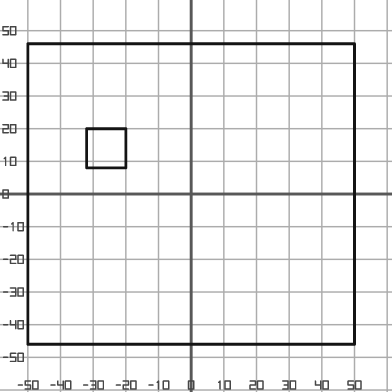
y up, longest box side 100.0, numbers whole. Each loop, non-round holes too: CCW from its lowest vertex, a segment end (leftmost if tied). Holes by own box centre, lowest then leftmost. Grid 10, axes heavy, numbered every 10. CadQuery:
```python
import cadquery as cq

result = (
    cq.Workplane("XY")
    .moveTo(-50.0, -46.0)
    .lineTo(50.0, -46.0)
    .lineTo(50.0, 46.0)
    .lineTo(-50.0, 46.0)
    .close()
    .moveTo(-32.0, 8.0)
    .lineTo(-20.0, 8.0)
    .lineTo(-20.0, 20.0)
    .lineTo(-32.0, 20.0)
    .close()
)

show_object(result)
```